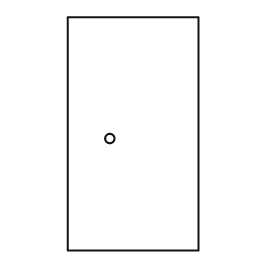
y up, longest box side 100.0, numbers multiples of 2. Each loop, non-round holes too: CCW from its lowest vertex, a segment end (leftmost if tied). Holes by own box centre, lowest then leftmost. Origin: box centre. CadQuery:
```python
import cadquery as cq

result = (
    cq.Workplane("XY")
    .moveTo(-28.0, -50.0)
    .lineTo(28.0, -50.0)
    .lineTo(28.0, 50.0)
    .lineTo(-28.0, 50.0)
    .close()
    .moveTo(-10.0, -2.0)
    .circle(2.0)
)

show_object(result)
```